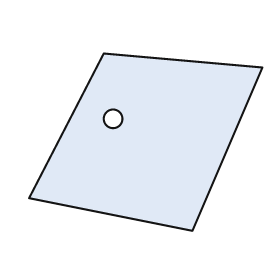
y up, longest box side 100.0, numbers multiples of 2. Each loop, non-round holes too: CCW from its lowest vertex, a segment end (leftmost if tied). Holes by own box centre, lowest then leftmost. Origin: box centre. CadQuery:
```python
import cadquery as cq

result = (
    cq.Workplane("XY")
    .moveTo(20.0, -38.0)
    .lineTo(50.0, 32.0)
    .lineTo(-18.0, 38.0)
    .lineTo(-50.0, -24.0)
    .close()
    .moveTo(-14.0, 10.0)
    .circle(4.0)
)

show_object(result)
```